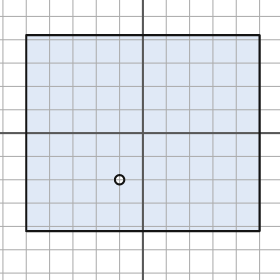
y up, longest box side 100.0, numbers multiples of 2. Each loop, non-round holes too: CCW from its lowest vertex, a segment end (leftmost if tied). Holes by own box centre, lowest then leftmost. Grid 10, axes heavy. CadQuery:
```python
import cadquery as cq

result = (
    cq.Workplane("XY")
    .moveTo(-50.0, -42.0)
    .lineTo(50.0, -42.0)
    .lineTo(50.0, 42.0)
    .lineTo(-50.0, 42.0)
    .close()
    .moveTo(-10.0, -20.0)
    .circle(2.0)
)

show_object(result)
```